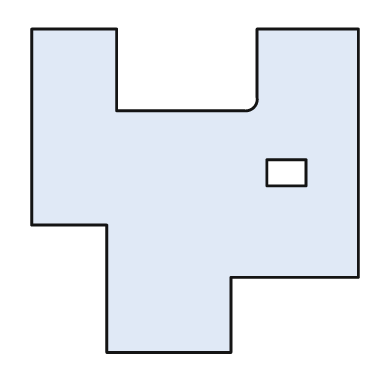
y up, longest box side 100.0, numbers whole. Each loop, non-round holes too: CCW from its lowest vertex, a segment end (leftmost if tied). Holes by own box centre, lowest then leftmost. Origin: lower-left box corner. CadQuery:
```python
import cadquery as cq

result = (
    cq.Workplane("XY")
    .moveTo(23.0, 0.0)
    .lineTo(61.0, 0.0)
    .lineTo(61.0, 23.0)
    .lineTo(100.0, 23.0)
    .lineTo(100.0, 99.0)
    .lineTo(69.0, 99.0)
    .lineTo(69.0, 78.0)
    .threePointArc((68.0, 75.0), (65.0, 74.0))
    .lineTo(26.0, 74.0)
    .lineTo(26.0, 99.0)
    .lineTo(0.0, 99.0)
    .lineTo(0.0, 39.0)
    .lineTo(23.0, 39.0)
    .close()
    .moveTo(72.0, 51.0)
    .lineTo(84.0, 51.0)
    .lineTo(84.0, 59.0)
    .lineTo(72.0, 59.0)
    .close()
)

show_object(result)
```